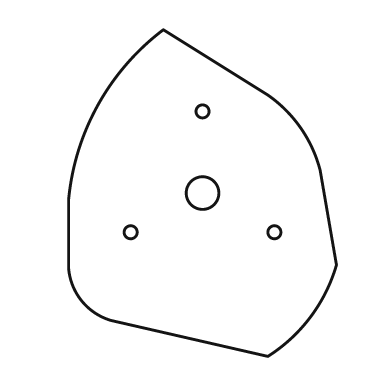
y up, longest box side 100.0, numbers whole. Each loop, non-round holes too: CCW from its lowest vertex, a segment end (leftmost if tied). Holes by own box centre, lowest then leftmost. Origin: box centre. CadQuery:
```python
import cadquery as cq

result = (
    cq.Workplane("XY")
    .moveTo(20.0, -50.0)
    .threePointArc((33.0, -38.0), (41.0, -22.0))
    .lineTo(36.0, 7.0)
    .threePointArc((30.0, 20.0), (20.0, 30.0))
    .lineTo(-12.0, 50.0)
    .threePointArc((-32.0, 27.0), (-41.0, -2.0))
    .lineTo(-41.0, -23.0)
    .threePointArc((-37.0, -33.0), (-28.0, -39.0))
    .close()
    .moveTo(-22.0, -12.0)
    .circle(2.0)
    .moveTo(22.0, -12.0)
    .circle(2.0)
    .moveTo(0.0, 0.0)
    .circle(5.0)
    .moveTo(0.0, 25.0)
    .circle(2.0)
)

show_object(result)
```